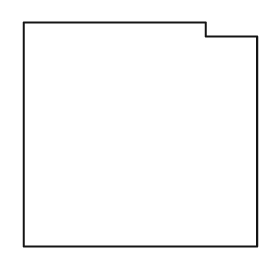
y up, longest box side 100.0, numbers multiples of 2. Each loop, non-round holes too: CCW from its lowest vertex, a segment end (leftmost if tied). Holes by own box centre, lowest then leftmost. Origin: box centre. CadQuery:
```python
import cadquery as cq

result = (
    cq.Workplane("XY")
    .moveTo(-50.0, -48.0)
    .lineTo(50.0, -48.0)
    .lineTo(50.0, 42.0)
    .lineTo(28.0, 42.0)
    .lineTo(28.0, 48.0)
    .lineTo(-50.0, 48.0)
    .close()
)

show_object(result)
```